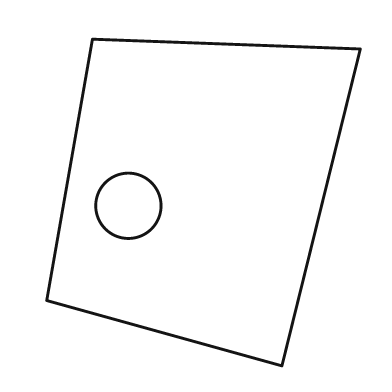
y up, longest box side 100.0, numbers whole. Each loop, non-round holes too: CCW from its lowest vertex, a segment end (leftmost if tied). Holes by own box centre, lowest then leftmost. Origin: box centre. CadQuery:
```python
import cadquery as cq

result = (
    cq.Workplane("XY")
    .moveTo(24.0, -50.0)
    .lineTo(48.0, 47.0)
    .lineTo(-34.0, 50.0)
    .lineTo(-48.0, -30.0)
    .close()
    .moveTo(-23.0, -1.0)
    .circle(10.0)
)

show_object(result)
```